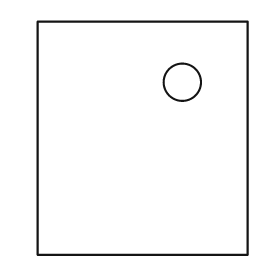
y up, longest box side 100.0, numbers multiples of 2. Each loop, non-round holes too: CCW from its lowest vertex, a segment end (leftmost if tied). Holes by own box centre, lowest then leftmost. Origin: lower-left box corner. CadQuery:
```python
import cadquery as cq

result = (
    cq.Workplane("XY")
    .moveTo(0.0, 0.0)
    .lineTo(90.0, 0.0)
    .lineTo(90.0, 100.0)
    .lineTo(0.0, 100.0)
    .close()
    .moveTo(62.0, 74.0)
    .circle(8.0)
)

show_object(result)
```